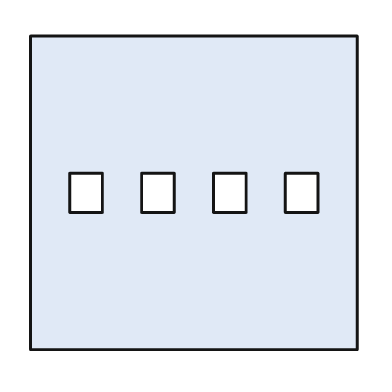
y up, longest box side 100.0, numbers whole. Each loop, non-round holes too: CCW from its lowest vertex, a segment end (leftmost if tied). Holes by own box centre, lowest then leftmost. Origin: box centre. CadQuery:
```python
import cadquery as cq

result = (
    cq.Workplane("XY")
    .moveTo(-50.0, -48.0)
    .lineTo(50.0, -48.0)
    .lineTo(50.0, 48.0)
    .lineTo(-50.0, 48.0)
    .close()
    .moveTo(-38.0, -6.0)
    .lineTo(-28.0, -6.0)
    .lineTo(-28.0, 6.0)
    .lineTo(-38.0, 6.0)
    .close()
    .moveTo(-16.0, -6.0)
    .lineTo(-6.0, -6.0)
    .lineTo(-6.0, 6.0)
    .lineTo(-16.0, 6.0)
    .close()
    .moveTo(6.0, -6.0)
    .lineTo(16.0, -6.0)
    .lineTo(16.0, 6.0)
    .lineTo(6.0, 6.0)
    .close()
    .moveTo(28.0, -6.0)
    .lineTo(38.0, -6.0)
    .lineTo(38.0, 6.0)
    .lineTo(28.0, 6.0)
    .close()
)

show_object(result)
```